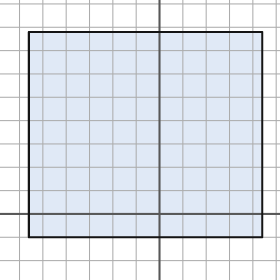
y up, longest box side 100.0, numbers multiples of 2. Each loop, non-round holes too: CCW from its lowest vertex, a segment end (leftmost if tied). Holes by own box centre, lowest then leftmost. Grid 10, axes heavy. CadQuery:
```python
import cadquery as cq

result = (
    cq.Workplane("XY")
    .moveTo(-56.0, -10.0)
    .lineTo(44.0, -10.0)
    .lineTo(44.0, 78.0)
    .lineTo(-56.0, 78.0)
    .close()
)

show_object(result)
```